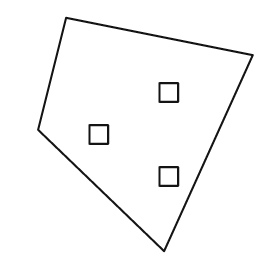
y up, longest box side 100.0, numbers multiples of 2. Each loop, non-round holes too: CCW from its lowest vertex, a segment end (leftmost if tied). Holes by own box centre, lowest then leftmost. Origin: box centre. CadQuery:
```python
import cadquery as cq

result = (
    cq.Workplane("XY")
    .moveTo(8.0, -50.0)
    .lineTo(46.0, 34.0)
    .lineTo(-34.0, 50.0)
    .lineTo(-46.0, 2.0)
    .close()
    .moveTo(6.0, -22.0)
    .lineTo(14.0, -22.0)
    .lineTo(14.0, -14.0)
    .lineTo(6.0, -14.0)
    .close()
    .moveTo(-24.0, -4.0)
    .lineTo(-16.0, -4.0)
    .lineTo(-16.0, 4.0)
    .lineTo(-24.0, 4.0)
    .close()
    .moveTo(6.0, 14.0)
    .lineTo(14.0, 14.0)
    .lineTo(14.0, 22.0)
    .lineTo(6.0, 22.0)
    .close()
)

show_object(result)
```